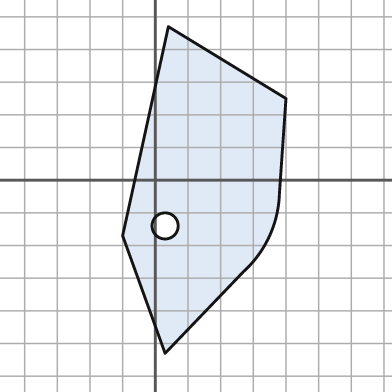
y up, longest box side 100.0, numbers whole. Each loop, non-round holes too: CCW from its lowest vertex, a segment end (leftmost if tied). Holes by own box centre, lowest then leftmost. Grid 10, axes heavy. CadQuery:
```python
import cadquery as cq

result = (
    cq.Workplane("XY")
    .moveTo(3.0, -53.0)
    .lineTo(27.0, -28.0)
    .threePointArc((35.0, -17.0), (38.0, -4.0))
    .lineTo(40.0, 25.0)
    .lineTo(4.0, 47.0)
    .lineTo(-10.0, -17.0)
    .close()
    .moveTo(3.0, -14.0)
    .circle(4.0)
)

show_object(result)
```